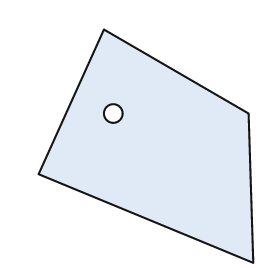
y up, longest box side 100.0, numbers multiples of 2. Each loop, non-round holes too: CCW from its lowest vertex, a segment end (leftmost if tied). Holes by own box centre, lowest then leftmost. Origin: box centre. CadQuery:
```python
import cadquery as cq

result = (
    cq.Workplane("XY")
    .moveTo(46.0, -50.0)
    .lineTo(44.0, 14.0)
    .lineTo(-18.0, 50.0)
    .lineTo(-46.0, -12.0)
    .close()
    .moveTo(-14.0, 14.0)
    .circle(4.0)
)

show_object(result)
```